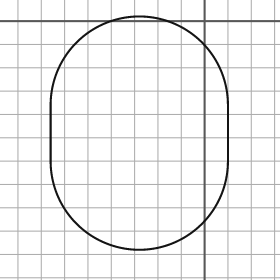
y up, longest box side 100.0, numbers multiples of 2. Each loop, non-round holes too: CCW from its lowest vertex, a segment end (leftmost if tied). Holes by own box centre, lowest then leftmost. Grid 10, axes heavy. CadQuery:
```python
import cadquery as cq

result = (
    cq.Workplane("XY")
    .moveTo(-66.0, -60.0)
    .threePointArc((-28.0, -98.0), (10.0, -60.0))
    .lineTo(10.0, -36.0)
    .threePointArc((-28.0, 2.0), (-66.0, -36.0))
    .close()
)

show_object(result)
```